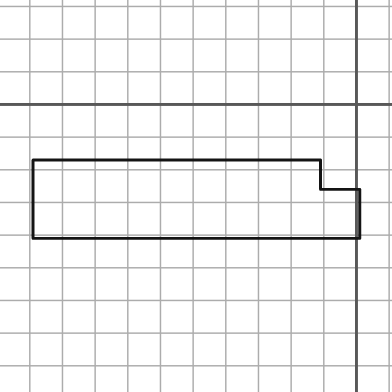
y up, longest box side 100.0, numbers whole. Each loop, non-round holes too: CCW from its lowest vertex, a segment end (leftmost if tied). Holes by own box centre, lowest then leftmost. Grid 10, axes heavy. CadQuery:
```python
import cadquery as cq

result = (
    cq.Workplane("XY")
    .moveTo(-99.0, -41.0)
    .lineTo(1.0, -41.0)
    .lineTo(1.0, -26.0)
    .lineTo(-11.0, -26.0)
    .lineTo(-11.0, -17.0)
    .lineTo(-99.0, -17.0)
    .close()
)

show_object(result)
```